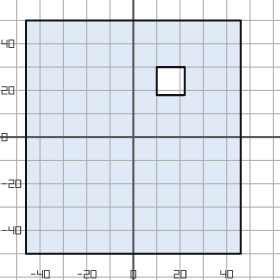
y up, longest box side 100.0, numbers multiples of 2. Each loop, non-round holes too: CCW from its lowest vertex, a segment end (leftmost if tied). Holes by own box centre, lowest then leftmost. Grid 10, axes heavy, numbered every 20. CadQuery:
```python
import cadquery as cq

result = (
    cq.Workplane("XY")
    .moveTo(-46.0, -50.0)
    .lineTo(46.0, -50.0)
    .lineTo(46.0, 50.0)
    .lineTo(-46.0, 50.0)
    .close()
    .moveTo(10.0, 18.0)
    .lineTo(22.0, 18.0)
    .lineTo(22.0, 30.0)
    .lineTo(10.0, 30.0)
    .close()
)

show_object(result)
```